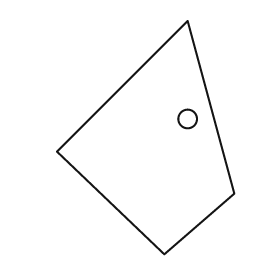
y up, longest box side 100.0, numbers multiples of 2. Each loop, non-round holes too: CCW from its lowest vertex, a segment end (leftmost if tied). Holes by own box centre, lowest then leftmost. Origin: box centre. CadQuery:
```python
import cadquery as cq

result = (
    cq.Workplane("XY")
    .moveTo(8.0, -50.0)
    .lineTo(38.0, -24.0)
    .lineTo(18.0, 50.0)
    .lineTo(-38.0, -6.0)
    .close()
    .moveTo(18.0, 8.0)
    .circle(4.0)
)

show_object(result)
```